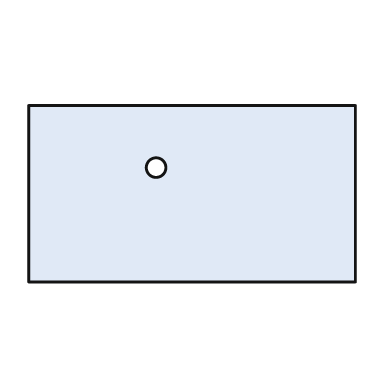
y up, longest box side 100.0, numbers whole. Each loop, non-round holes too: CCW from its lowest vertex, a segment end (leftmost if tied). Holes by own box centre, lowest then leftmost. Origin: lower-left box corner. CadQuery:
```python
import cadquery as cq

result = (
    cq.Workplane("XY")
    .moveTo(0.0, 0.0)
    .lineTo(100.0, 0.0)
    .lineTo(100.0, 54.0)
    .lineTo(0.0, 54.0)
    .close()
    .moveTo(39.0, 35.0)
    .circle(3.0)
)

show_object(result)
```